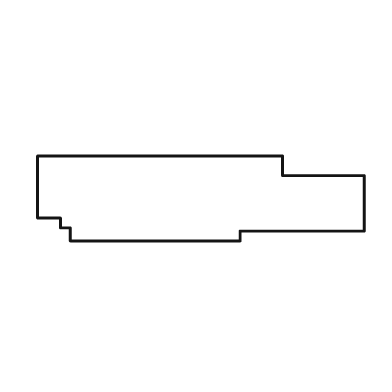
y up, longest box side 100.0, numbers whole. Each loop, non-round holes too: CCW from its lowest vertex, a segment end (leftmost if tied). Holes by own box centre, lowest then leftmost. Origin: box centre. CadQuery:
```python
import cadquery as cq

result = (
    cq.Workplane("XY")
    .moveTo(-40.0, -13.0)
    .lineTo(12.0, -13.0)
    .lineTo(12.0, -10.0)
    .lineTo(50.0, -10.0)
    .lineTo(50.0, 7.0)
    .lineTo(25.0, 7.0)
    .lineTo(25.0, 13.0)
    .lineTo(-50.0, 13.0)
    .lineTo(-50.0, -6.0)
    .lineTo(-43.0, -6.0)
    .lineTo(-43.0, -9.0)
    .lineTo(-40.0, -9.0)
    .close()
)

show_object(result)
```